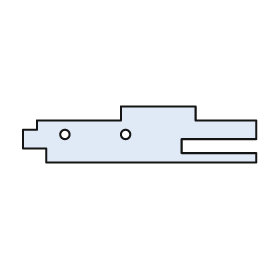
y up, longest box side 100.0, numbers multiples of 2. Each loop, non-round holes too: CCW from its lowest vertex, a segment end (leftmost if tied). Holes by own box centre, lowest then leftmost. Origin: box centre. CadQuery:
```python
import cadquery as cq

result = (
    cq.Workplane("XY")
    .moveTo(-40.0, -12.0)
    .lineTo(50.0, -12.0)
    .lineTo(50.0, -8.0)
    .lineTo(18.0, -8.0)
    .lineTo(18.0, -2.0)
    .lineTo(50.0, -2.0)
    .lineTo(50.0, 6.0)
    .lineTo(24.0, 6.0)
    .lineTo(24.0, 12.0)
    .lineTo(-8.0, 12.0)
    .lineTo(-8.0, 6.0)
    .lineTo(-44.0, 6.0)
    .lineTo(-44.0, 2.0)
    .lineTo(-50.0, 2.0)
    .lineTo(-50.0, -6.0)
    .lineTo(-40.0, -6.0)
    .close()
    .moveTo(-32.0, 0.0)
    .circle(2.0)
    .moveTo(-6.0, 0.0)
    .circle(2.0)
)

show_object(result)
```